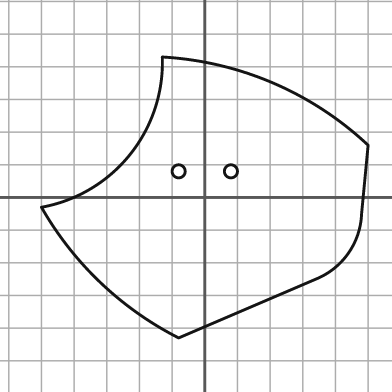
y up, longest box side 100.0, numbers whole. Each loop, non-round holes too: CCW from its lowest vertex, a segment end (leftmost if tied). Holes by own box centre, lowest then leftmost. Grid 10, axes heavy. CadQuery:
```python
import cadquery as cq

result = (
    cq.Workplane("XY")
    .moveTo(-8.0, -43.0)
    .lineTo(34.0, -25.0)
    .threePointArc((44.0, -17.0), (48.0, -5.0))
    .lineTo(50.0, 16.0)
    .threePointArc((21.0, 35.0), (-13.0, 43.0))
    .threePointArc((-23.0, 13.0), (-50.0, -3.0))
    .threePointArc((-32.0, -26.0), (-8.0, -43.0))
    .close()
    .moveTo(-8.0, 8.0)
    .circle(2.0)
    .moveTo(8.0, 8.0)
    .circle(2.0)
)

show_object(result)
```